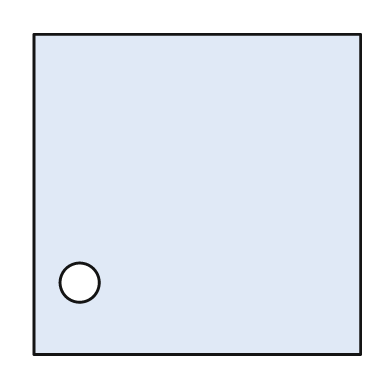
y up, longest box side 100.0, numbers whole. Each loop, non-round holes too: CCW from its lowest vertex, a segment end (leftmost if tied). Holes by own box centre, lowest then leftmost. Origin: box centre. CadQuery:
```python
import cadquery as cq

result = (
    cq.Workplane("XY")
    .moveTo(-50.0, -49.0)
    .lineTo(50.0, -49.0)
    .lineTo(50.0, 49.0)
    .lineTo(-50.0, 49.0)
    .close()
    .moveTo(-36.0, -27.0)
    .circle(6.0)
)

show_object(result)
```